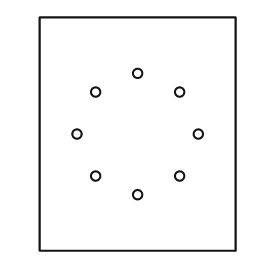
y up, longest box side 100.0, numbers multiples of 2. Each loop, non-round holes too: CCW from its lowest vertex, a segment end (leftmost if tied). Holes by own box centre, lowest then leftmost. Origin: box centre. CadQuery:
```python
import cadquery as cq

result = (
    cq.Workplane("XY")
    .moveTo(-42.0, -50.0)
    .lineTo(42.0, -50.0)
    .lineTo(42.0, 50.0)
    .lineTo(-42.0, 50.0)
    .close()
    .moveTo(0.0, -26.0)
    .circle(2.0)
    .moveTo(-18.0, -18.0)
    .circle(2.0)
    .moveTo(18.0, -18.0)
    .circle(2.0)
    .moveTo(-26.0, 0.0)
    .circle(2.0)
    .moveTo(26.0, 0.0)
    .circle(2.0)
    .moveTo(-18.0, 18.0)
    .circle(2.0)
    .moveTo(18.0, 18.0)
    .circle(2.0)
    .moveTo(0.0, 26.0)
    .circle(2.0)
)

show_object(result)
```